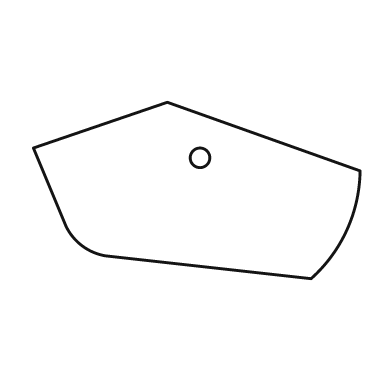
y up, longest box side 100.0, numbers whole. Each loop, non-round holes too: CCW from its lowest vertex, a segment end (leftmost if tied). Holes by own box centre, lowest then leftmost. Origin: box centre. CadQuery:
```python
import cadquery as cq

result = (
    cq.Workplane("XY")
    .moveTo(35.0, -27.0)
    .threePointArc((46.0, -12.0), (50.0, 6.0))
    .lineTo(-9.0, 27.0)
    .lineTo(-50.0, 13.0)
    .lineTo(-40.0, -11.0)
    .threePointArc((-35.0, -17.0), (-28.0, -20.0))
    .close()
    .moveTo(1.0, 10.0)
    .circle(3.0)
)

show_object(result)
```